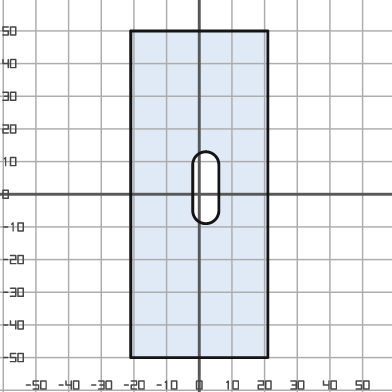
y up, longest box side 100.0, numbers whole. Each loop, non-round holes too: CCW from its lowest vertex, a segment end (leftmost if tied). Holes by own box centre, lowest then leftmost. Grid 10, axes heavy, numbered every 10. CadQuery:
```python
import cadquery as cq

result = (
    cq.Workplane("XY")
    .moveTo(-21.0, -50.0)
    .lineTo(21.0, -50.0)
    .lineTo(21.0, 50.0)
    .lineTo(-21.0, 50.0)
    .close()
    .moveTo(-2.0, -5.0)
    .threePointArc((2.0, -9.0), (6.0, -5.0))
    .lineTo(6.0, 9.0)
    .threePointArc((2.0, 13.0), (-2.0, 9.0))
    .close()
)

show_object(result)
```